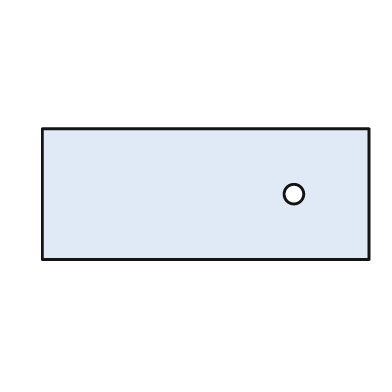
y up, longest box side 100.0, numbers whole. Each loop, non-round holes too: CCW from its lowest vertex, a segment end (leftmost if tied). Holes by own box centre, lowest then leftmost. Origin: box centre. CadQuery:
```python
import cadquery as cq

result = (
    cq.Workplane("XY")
    .moveTo(-50.0, -20.0)
    .lineTo(50.0, -20.0)
    .lineTo(50.0, 20.0)
    .lineTo(-50.0, 20.0)
    .close()
    .moveTo(27.0, 0.0)
    .circle(3.0)
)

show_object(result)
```